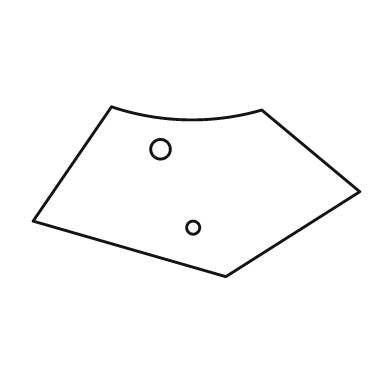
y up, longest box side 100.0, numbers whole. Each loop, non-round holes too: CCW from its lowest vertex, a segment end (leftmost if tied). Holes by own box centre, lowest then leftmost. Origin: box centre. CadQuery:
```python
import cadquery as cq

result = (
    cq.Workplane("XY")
    .moveTo(9.0, -26.0)
    .lineTo(50.0, 0.0)
    .lineTo(20.0, 25.0)
    .threePointArc((-3.0, 22.0), (-26.0, 26.0))
    .lineTo(-50.0, -9.0)
    .close()
    .moveTo(-1.0, -11.0)
    .circle(2.0)
    .moveTo(-11.0, 13.0)
    .circle(3.0)
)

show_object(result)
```